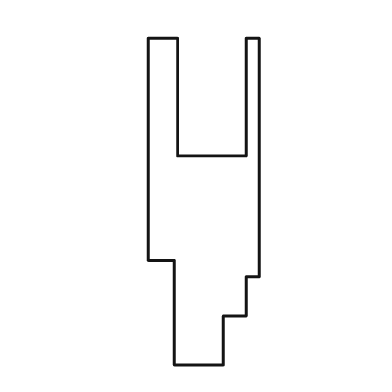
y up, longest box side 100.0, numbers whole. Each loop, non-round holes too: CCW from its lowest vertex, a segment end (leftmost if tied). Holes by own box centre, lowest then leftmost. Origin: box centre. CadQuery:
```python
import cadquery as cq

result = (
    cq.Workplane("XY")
    .moveTo(-9.0, -50.0)
    .lineTo(6.0, -50.0)
    .lineTo(6.0, -35.0)
    .lineTo(13.0, -35.0)
    .lineTo(13.0, -23.0)
    .lineTo(17.0, -23.0)
    .lineTo(17.0, 50.0)
    .lineTo(13.0, 50.0)
    .lineTo(13.0, 14.0)
    .lineTo(-8.0, 14.0)
    .lineTo(-8.0, 50.0)
    .lineTo(-17.0, 50.0)
    .lineTo(-17.0, -18.0)
    .lineTo(-9.0, -18.0)
    .close()
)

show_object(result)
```